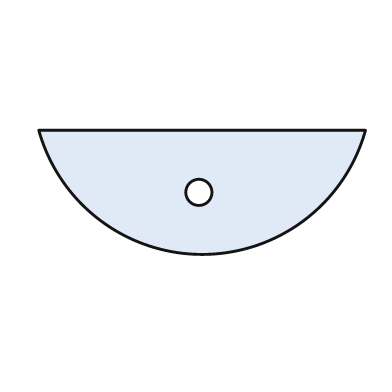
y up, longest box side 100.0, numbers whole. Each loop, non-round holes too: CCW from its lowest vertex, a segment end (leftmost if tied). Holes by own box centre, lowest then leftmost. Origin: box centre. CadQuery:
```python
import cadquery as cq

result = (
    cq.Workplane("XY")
    .moveTo(-50.0, 19.0)
    .threePointArc((0.0, -19.0), (50.0, 19.0))
    .close()
    .moveTo(-1.0, 0.0)
    .circle(4.0)
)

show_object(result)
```